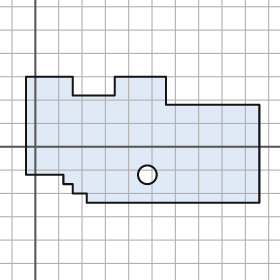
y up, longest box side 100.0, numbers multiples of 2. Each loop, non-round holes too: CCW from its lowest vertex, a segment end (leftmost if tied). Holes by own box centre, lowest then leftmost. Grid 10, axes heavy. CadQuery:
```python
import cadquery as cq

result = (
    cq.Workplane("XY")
    .moveTo(22.0, -24.0)
    .lineTo(96.0, -24.0)
    .lineTo(96.0, 18.0)
    .lineTo(56.0, 18.0)
    .lineTo(56.0, 30.0)
    .lineTo(34.0, 30.0)
    .lineTo(34.0, 22.0)
    .lineTo(16.0, 22.0)
    .lineTo(16.0, 30.0)
    .lineTo(-4.0, 30.0)
    .lineTo(-4.0, -12.0)
    .lineTo(12.0, -12.0)
    .lineTo(12.0, -16.0)
    .lineTo(16.0, -16.0)
    .lineTo(16.0, -20.0)
    .lineTo(22.0, -20.0)
    .close()
    .moveTo(48.0, -12.0)
    .circle(4.0)
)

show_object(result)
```